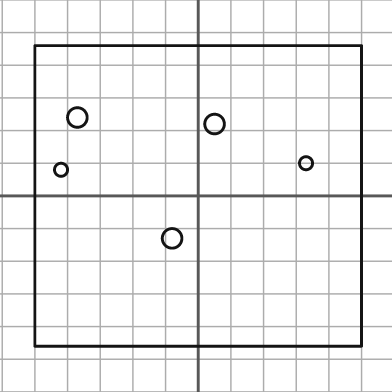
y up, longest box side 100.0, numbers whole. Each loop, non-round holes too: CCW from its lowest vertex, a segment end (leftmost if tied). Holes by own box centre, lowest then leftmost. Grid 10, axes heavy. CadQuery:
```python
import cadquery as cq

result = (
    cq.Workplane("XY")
    .moveTo(-50.0, -46.0)
    .lineTo(50.0, -46.0)
    .lineTo(50.0, 46.0)
    .lineTo(-50.0, 46.0)
    .close()
    .moveTo(-8.0, -13.0)
    .circle(3.0)
    .moveTo(-42.0, 8.0)
    .circle(2.0)
    .moveTo(33.0, 10.0)
    .circle(2.0)
    .moveTo(5.0, 22.0)
    .circle(3.0)
    .moveTo(-37.0, 24.0)
    .circle(3.0)
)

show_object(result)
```